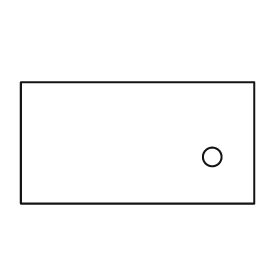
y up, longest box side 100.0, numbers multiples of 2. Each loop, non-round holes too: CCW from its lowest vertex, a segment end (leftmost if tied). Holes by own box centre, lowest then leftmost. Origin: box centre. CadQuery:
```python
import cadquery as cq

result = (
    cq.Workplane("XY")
    .moveTo(-50.0, -26.0)
    .lineTo(50.0, -26.0)
    .lineTo(50.0, 26.0)
    .lineTo(-50.0, 26.0)
    .close()
    .moveTo(32.0, -6.0)
    .circle(4.0)
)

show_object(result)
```